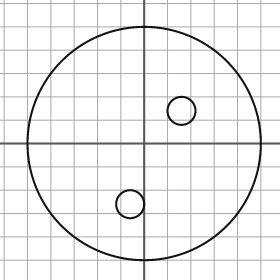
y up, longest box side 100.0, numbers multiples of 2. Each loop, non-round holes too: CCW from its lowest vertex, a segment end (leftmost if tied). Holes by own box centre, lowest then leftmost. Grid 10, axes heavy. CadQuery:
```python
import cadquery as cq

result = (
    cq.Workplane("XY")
    .moveTo(0.0, 0.0)
    .circle(50.0)
    .moveTo(-6.0, -26.0)
    .circle(6.0)
    .moveTo(16.0, 14.0)
    .circle(6.0)
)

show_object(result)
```